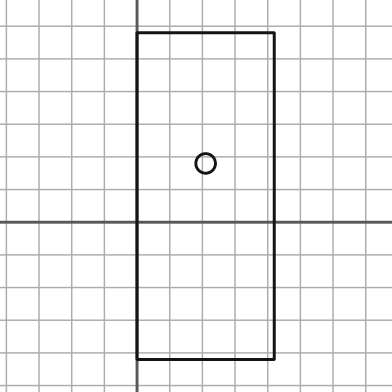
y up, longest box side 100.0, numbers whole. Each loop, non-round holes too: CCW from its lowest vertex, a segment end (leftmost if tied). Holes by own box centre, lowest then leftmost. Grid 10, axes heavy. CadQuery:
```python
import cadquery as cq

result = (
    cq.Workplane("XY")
    .moveTo(0.0, -42.0)
    .lineTo(42.0, -42.0)
    .lineTo(42.0, 58.0)
    .lineTo(0.0, 58.0)
    .close()
    .moveTo(21.0, 18.0)
    .circle(3.0)
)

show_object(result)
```